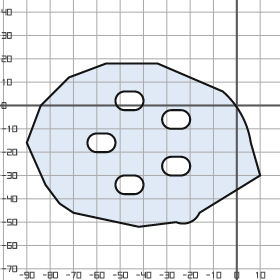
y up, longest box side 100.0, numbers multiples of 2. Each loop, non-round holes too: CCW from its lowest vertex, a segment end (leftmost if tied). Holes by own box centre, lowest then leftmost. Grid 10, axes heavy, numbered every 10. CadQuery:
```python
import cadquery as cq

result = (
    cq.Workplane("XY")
    .moveTo(-42.0, -52.0)
    .lineTo(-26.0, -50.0)
    .threePointArc((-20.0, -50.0), (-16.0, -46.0))
    .lineTo(10.0, -30.0)
    .lineTo(6.0, -16.0)
    .threePointArc((2.0, -4.0), (-6.0, 6.0))
    .lineTo(-34.0, 18.0)
    .lineTo(-56.0, 18.0)
    .lineTo(-72.0, 12.0)
    .lineTo(-84.0, 0.0)
    .lineTo(-90.0, -16.0)
    .lineTo(-82.0, -34.0)
    .lineTo(-76.0, -42.0)
    .lineTo(-70.0, -46.0)
    .close()
    .moveTo(-48.0, -38.0)
    .lineTo(-44.0, -38.0)
    .threePointArc((-40.0, -34.0), (-44.0, -30.0))
    .lineTo(-48.0, -30.0)
    .threePointArc((-52.0, -34.0), (-48.0, -38.0))
    .close()
    .moveTo(-28.0, -30.0)
    .lineTo(-24.0, -30.0)
    .threePointArc((-20.0, -26.0), (-24.0, -22.0))
    .lineTo(-28.0, -22.0)
    .threePointArc((-32.0, -26.0), (-28.0, -30.0))
    .close()
    .moveTo(-60.0, -20.0)
    .lineTo(-56.0, -20.0)
    .threePointArc((-52.0, -16.0), (-56.0, -12.0))
    .lineTo(-60.0, -12.0)
    .threePointArc((-64.0, -16.0), (-60.0, -20.0))
    .close()
    .moveTo(-28.0, -10.0)
    .lineTo(-24.0, -10.0)
    .threePointArc((-20.0, -6.0), (-24.0, -2.0))
    .lineTo(-28.0, -2.0)
    .threePointArc((-32.0, -6.0), (-28.0, -10.0))
    .close()
    .moveTo(-48.0, -2.0)
    .lineTo(-44.0, -2.0)
    .threePointArc((-40.0, 2.0), (-44.0, 6.0))
    .lineTo(-48.0, 6.0)
    .threePointArc((-52.0, 2.0), (-48.0, -2.0))
    .close()
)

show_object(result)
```